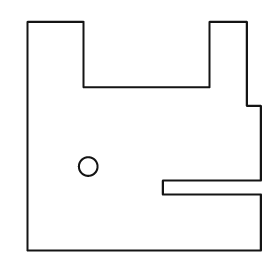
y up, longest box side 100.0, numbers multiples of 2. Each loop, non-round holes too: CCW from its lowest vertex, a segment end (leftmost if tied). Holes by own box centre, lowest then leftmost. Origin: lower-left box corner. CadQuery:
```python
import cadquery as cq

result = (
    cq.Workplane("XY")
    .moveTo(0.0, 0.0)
    .lineTo(100.0, 0.0)
    .lineTo(100.0, 24.0)
    .lineTo(58.0, 24.0)
    .lineTo(58.0, 30.0)
    .lineTo(100.0, 30.0)
    .lineTo(100.0, 62.0)
    .lineTo(94.0, 62.0)
    .lineTo(94.0, 98.0)
    .lineTo(78.0, 98.0)
    .lineTo(78.0, 70.0)
    .lineTo(24.0, 70.0)
    .lineTo(24.0, 98.0)
    .lineTo(0.0, 98.0)
    .close()
    .moveTo(26.0, 36.0)
    .circle(4.0)
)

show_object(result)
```